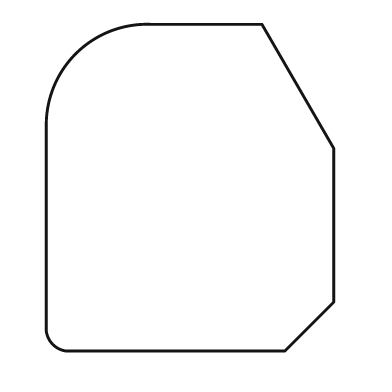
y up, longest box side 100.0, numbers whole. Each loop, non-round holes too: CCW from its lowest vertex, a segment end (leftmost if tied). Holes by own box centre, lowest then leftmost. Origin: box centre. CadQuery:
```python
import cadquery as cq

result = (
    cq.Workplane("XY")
    .moveTo(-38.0, -50.0)
    .lineTo(29.0, -50.0)
    .lineTo(44.0, -35.0)
    .lineTo(44.0, 12.0)
    .lineTo(22.0, 50.0)
    .lineTo(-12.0, 50.0)
    .threePointArc((-35.0, 41.0), (-44.0, 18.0))
    .lineTo(-44.0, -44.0)
    .threePointArc((-42.0, -48.0), (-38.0, -50.0))
    .close()
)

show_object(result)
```